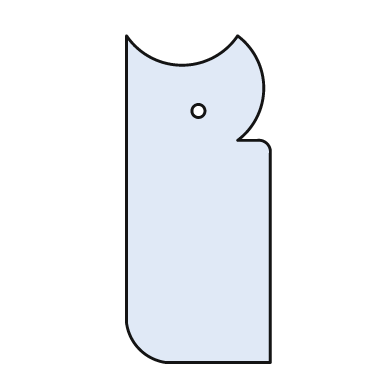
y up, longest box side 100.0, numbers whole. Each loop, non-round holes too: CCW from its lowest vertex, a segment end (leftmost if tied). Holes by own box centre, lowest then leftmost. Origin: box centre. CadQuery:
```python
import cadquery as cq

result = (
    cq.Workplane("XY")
    .moveTo(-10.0, -50.0)
    .lineTo(22.0, -50.0)
    .lineTo(22.0, 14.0)
    .threePointArc((21.0, 17.0), (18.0, 18.0))
    .lineTo(12.0, 18.0)
    .threePointArc((20.0, 34.0), (12.0, 50.0))
    .threePointArc((-5.0, 41.0), (-22.0, 50.0))
    .lineTo(-22.0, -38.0)
    .threePointArc((-18.0, -46.0), (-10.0, -50.0))
    .close()
    .moveTo(0.0, 27.0)
    .circle(2.0)
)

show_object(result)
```